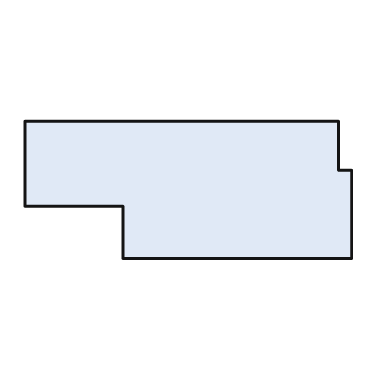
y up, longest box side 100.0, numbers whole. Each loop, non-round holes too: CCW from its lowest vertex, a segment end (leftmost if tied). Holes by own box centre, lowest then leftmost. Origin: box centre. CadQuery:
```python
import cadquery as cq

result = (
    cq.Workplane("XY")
    .moveTo(-20.0, -21.0)
    .lineTo(50.0, -21.0)
    .lineTo(50.0, 6.0)
    .lineTo(46.0, 6.0)
    .lineTo(46.0, 21.0)
    .lineTo(-50.0, 21.0)
    .lineTo(-50.0, -5.0)
    .lineTo(-20.0, -5.0)
    .close()
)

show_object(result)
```